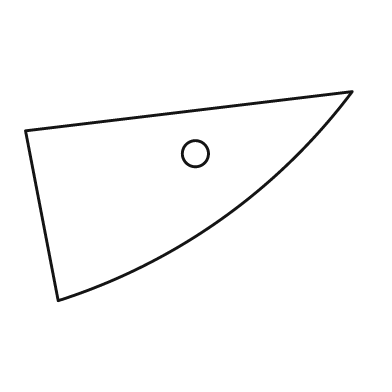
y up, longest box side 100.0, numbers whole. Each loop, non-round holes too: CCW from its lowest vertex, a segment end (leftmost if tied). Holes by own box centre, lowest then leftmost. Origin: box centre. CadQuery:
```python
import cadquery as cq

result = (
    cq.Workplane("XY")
    .moveTo(-40.0, -32.0)
    .threePointArc((10.0, -7.0), (50.0, 32.0))
    .lineTo(-50.0, 20.0)
    .close()
    .moveTo(2.0, 13.0)
    .circle(4.0)
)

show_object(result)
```